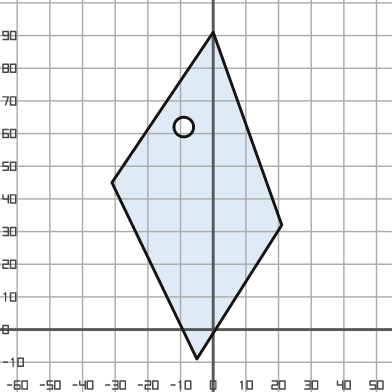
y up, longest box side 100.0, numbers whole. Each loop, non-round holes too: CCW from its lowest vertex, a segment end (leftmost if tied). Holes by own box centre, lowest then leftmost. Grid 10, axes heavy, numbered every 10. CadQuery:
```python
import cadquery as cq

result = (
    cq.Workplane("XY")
    .moveTo(-5.0, -9.0)
    .lineTo(21.0, 32.0)
    .lineTo(0.0, 91.0)
    .lineTo(-31.0, 45.0)
    .close()
    .moveTo(-9.0, 62.0)
    .circle(3.0)
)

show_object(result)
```